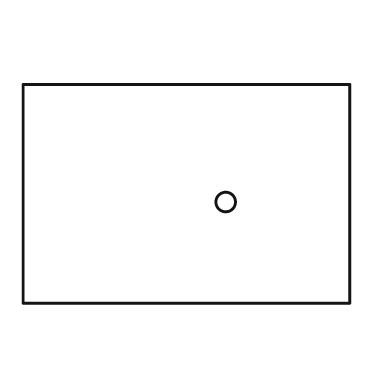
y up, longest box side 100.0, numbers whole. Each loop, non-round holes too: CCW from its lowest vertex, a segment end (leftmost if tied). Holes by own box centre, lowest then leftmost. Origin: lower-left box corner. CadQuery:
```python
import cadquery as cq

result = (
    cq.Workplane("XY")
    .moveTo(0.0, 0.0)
    .lineTo(100.0, 0.0)
    .lineTo(100.0, 67.0)
    .lineTo(0.0, 67.0)
    .close()
    .moveTo(62.0, 31.0)
    .circle(3.0)
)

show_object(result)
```